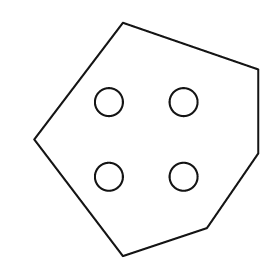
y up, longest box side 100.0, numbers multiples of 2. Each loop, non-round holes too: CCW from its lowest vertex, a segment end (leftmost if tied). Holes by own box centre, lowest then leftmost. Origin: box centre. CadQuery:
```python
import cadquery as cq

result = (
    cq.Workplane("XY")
    .moveTo(-10.0, -50.0)
    .lineTo(26.0, -38.0)
    .lineTo(48.0, -6.0)
    .lineTo(48.0, 30.0)
    .lineTo(-10.0, 50.0)
    .lineTo(-48.0, 0.0)
    .close()
    .moveTo(-16.0, -16.0)
    .circle(6.0)
    .moveTo(16.0, -16.0)
    .circle(6.0)
    .moveTo(-16.0, 16.0)
    .circle(6.0)
    .moveTo(16.0, 16.0)
    .circle(6.0)
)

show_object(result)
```